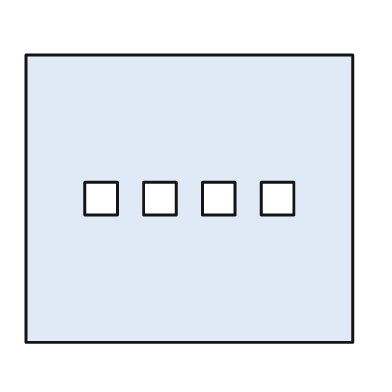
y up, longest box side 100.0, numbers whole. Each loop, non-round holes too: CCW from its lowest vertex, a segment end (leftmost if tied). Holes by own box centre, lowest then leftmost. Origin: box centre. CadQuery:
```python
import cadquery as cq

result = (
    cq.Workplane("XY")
    .moveTo(-50.0, -44.0)
    .lineTo(50.0, -44.0)
    .lineTo(50.0, 44.0)
    .lineTo(-50.0, 44.0)
    .close()
    .moveTo(-32.0, -5.0)
    .lineTo(-22.0, -5.0)
    .lineTo(-22.0, 5.0)
    .lineTo(-32.0, 5.0)
    .close()
    .moveTo(-14.0, -5.0)
    .lineTo(-4.0, -5.0)
    .lineTo(-4.0, 5.0)
    .lineTo(-14.0, 5.0)
    .close()
    .moveTo(4.0, -5.0)
    .lineTo(14.0, -5.0)
    .lineTo(14.0, 5.0)
    .lineTo(4.0, 5.0)
    .close()
    .moveTo(22.0, -5.0)
    .lineTo(32.0, -5.0)
    .lineTo(32.0, 5.0)
    .lineTo(22.0, 5.0)
    .close()
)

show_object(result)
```